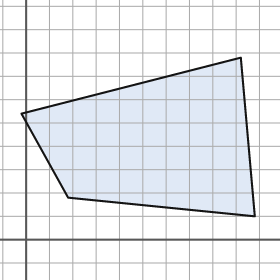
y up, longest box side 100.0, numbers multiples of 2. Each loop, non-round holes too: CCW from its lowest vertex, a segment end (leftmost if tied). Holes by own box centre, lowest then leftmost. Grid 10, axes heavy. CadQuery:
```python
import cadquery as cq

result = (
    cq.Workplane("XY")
    .moveTo(98.0, 10.0)
    .lineTo(92.0, 78.0)
    .lineTo(-2.0, 54.0)
    .lineTo(18.0, 18.0)
    .close()
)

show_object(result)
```